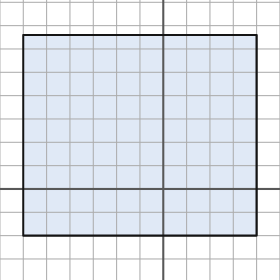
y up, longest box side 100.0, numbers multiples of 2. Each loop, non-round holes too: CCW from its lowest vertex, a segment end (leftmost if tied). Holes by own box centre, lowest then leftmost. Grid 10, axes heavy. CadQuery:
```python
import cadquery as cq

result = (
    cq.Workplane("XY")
    .moveTo(-60.0, -20.0)
    .lineTo(40.0, -20.0)
    .lineTo(40.0, 66.0)
    .lineTo(-60.0, 66.0)
    .close()
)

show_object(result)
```